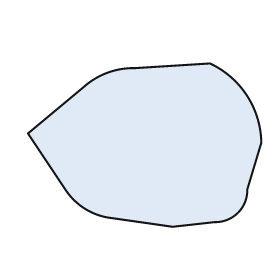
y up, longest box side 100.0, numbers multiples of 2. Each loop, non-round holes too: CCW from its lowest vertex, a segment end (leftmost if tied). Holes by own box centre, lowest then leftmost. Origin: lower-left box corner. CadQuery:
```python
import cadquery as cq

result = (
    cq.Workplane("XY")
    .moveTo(62.0, 0.0)
    .lineTo(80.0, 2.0)
    .threePointArc((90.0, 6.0), (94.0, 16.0))
    .lineTo(100.0, 36.0)
    .threePointArc((94.0, 56.0), (78.0, 70.0))
    .lineTo(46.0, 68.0)
    .threePointArc((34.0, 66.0), (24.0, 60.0))
    .lineTo(0.0, 40.0)
    .lineTo(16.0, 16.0)
    .threePointArc((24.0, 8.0), (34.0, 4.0))
    .close()
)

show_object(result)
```